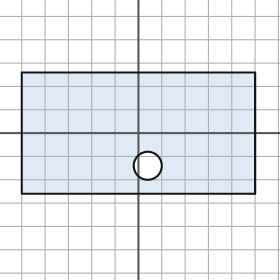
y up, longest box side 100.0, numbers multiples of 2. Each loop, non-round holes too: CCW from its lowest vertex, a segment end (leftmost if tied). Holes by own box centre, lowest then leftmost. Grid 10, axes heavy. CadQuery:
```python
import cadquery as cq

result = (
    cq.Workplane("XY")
    .moveTo(-50.0, -26.0)
    .lineTo(50.0, -26.0)
    .lineTo(50.0, 26.0)
    .lineTo(-50.0, 26.0)
    .close()
    .moveTo(4.0, -14.0)
    .circle(6.0)
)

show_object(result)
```